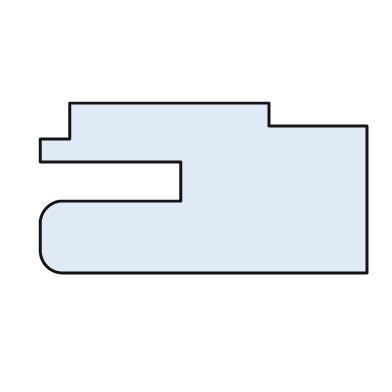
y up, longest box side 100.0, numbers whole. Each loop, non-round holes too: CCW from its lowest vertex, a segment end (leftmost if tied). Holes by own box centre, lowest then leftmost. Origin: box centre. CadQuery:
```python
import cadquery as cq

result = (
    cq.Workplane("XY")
    .moveTo(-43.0, -26.0)
    .lineTo(50.0, -26.0)
    .lineTo(50.0, 19.0)
    .lineTo(20.0, 19.0)
    .lineTo(20.0, 26.0)
    .lineTo(-41.0, 26.0)
    .lineTo(-41.0, 15.0)
    .lineTo(-50.0, 15.0)
    .lineTo(-50.0, 8.0)
    .lineTo(-7.0, 8.0)
    .lineTo(-7.0, -4.0)
    .lineTo(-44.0, -4.0)
    .threePointArc((-48.0, -6.0), (-50.0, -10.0))
    .lineTo(-50.0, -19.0)
    .threePointArc((-48.0, -24.0), (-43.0, -26.0))
    .close()
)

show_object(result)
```